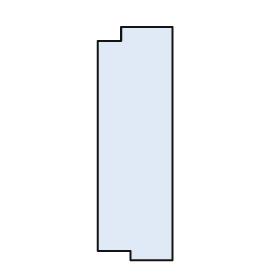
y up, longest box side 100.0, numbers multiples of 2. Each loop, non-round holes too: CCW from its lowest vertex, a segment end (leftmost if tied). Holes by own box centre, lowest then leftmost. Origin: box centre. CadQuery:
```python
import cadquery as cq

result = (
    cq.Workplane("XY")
    .moveTo(-2.0, -50.0)
    .lineTo(16.0, -50.0)
    .lineTo(16.0, 50.0)
    .lineTo(-6.0, 50.0)
    .lineTo(-6.0, 44.0)
    .lineTo(-16.0, 44.0)
    .lineTo(-16.0, -46.0)
    .lineTo(-2.0, -46.0)
    .close()
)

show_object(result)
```